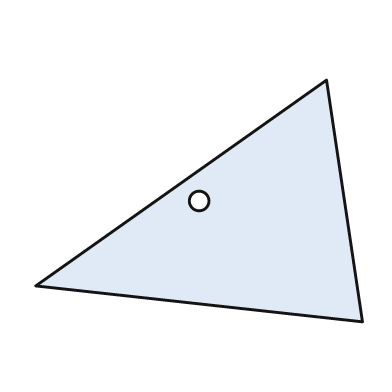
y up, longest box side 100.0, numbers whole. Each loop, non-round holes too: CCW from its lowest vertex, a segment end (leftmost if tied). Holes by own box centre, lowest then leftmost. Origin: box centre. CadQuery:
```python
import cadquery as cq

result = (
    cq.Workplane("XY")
    .moveTo(50.0, -37.0)
    .lineTo(39.0, 37.0)
    .lineTo(-50.0, -26.0)
    .close()
    .moveTo(0.0, 0.0)
    .circle(3.0)
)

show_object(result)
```